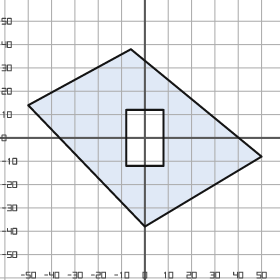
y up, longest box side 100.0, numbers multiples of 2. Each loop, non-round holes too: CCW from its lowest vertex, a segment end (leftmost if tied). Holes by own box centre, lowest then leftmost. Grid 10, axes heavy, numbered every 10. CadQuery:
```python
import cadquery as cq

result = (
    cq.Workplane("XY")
    .moveTo(0.0, -38.0)
    .lineTo(50.0, -8.0)
    .lineTo(-6.0, 38.0)
    .lineTo(-50.0, 14.0)
    .close()
    .moveTo(-8.0, -12.0)
    .lineTo(8.0, -12.0)
    .lineTo(8.0, 12.0)
    .lineTo(-8.0, 12.0)
    .close()
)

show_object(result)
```